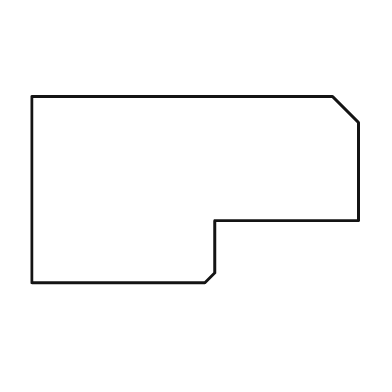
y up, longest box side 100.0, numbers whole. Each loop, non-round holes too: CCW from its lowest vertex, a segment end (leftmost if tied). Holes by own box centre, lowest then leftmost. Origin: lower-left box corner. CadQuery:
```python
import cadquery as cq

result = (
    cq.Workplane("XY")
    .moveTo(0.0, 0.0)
    .lineTo(53.0, 0.0)
    .lineTo(56.0, 3.0)
    .lineTo(56.0, 19.0)
    .lineTo(100.0, 19.0)
    .lineTo(100.0, 49.0)
    .lineTo(92.0, 57.0)
    .lineTo(0.0, 57.0)
    .close()
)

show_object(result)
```